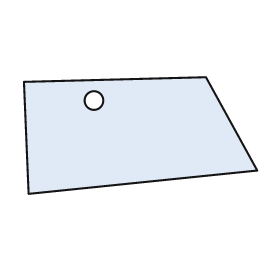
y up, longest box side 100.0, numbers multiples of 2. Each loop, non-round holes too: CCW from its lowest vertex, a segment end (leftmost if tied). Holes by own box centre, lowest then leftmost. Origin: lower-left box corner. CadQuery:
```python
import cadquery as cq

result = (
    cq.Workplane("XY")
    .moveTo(2.0, 0.0)
    .lineTo(100.0, 10.0)
    .lineTo(78.0, 50.0)
    .lineTo(0.0, 48.0)
    .close()
    .moveTo(30.0, 40.0)
    .circle(4.0)
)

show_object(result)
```